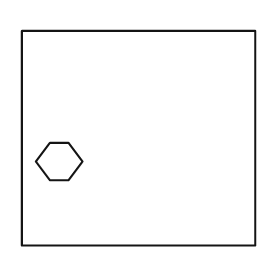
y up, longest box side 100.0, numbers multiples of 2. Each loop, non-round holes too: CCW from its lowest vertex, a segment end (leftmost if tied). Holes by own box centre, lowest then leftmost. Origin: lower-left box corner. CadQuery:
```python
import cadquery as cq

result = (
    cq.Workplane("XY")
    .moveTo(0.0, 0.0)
    .lineTo(100.0, 0.0)
    .lineTo(100.0, 92.0)
    .lineTo(0.0, 92.0)
    .close()
    .moveTo(12.0, 28.0)
    .lineTo(20.0, 28.0)
    .lineTo(26.0, 36.0)
    .lineTo(20.0, 44.0)
    .lineTo(12.0, 44.0)
    .lineTo(6.0, 36.0)
    .close()
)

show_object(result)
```